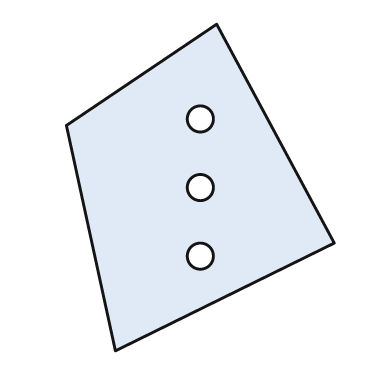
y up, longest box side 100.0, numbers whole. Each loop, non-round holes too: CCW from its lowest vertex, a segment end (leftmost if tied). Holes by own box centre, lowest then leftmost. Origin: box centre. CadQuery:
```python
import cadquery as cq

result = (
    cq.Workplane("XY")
    .moveTo(-26.0, -50.0)
    .lineTo(41.0, -17.0)
    .lineTo(5.0, 50.0)
    .lineTo(-41.0, 19.0)
    .close()
    .moveTo(0.0, -21.0)
    .circle(4.0)
    .moveTo(0.0, 0.0)
    .circle(4.0)
    .moveTo(0.0, 21.0)
    .circle(4.0)
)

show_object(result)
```